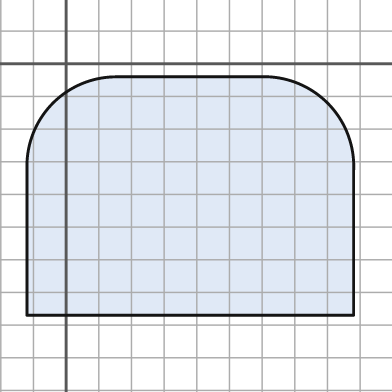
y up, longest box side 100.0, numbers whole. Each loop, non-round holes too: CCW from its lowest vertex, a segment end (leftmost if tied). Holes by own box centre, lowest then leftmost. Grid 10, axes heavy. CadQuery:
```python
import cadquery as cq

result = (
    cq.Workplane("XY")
    .moveTo(-12.0, -77.0)
    .lineTo(88.0, -77.0)
    .lineTo(88.0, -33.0)
    .threePointArc((80.0, -12.0), (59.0, -4.0))
    .lineTo(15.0, -4.0)
    .threePointArc((-4.0, -12.0), (-12.0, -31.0))
    .close()
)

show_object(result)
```